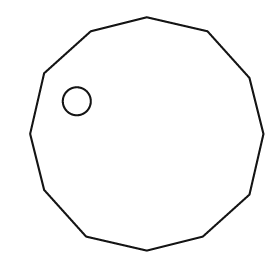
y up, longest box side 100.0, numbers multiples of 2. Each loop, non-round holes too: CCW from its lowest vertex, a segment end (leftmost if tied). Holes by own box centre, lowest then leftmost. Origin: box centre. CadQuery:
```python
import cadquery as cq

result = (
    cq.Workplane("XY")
    .moveTo(0.0, -50.0)
    .lineTo(24.0, -44.0)
    .lineTo(44.0, -26.0)
    .lineTo(50.0, 0.0)
    .lineTo(44.0, 24.0)
    .lineTo(26.0, 44.0)
    .lineTo(0.0, 50.0)
    .lineTo(-24.0, 44.0)
    .lineTo(-44.0, 26.0)
    .lineTo(-50.0, 0.0)
    .lineTo(-44.0, -24.0)
    .lineTo(-26.0, -44.0)
    .close()
    .moveTo(-30.0, 14.0)
    .circle(6.0)
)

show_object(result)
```